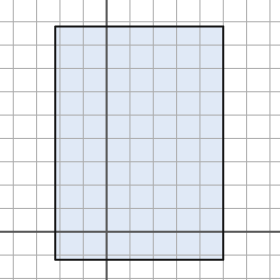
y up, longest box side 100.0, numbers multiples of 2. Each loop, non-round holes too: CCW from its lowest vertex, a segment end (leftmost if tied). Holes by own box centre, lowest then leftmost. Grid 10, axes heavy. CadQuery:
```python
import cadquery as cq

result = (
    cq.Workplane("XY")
    .moveTo(-22.0, -12.0)
    .lineTo(50.0, -12.0)
    .lineTo(50.0, 88.0)
    .lineTo(-22.0, 88.0)
    .close()
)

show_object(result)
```